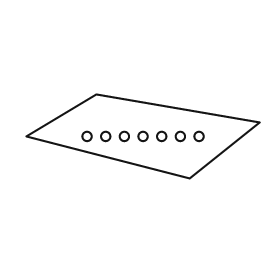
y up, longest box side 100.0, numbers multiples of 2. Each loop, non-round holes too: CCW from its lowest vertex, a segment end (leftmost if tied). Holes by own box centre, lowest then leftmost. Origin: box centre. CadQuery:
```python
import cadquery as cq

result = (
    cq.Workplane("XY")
    .moveTo(20.0, -18.0)
    .lineTo(50.0, 6.0)
    .lineTo(-20.0, 18.0)
    .lineTo(-50.0, 0.0)
    .close()
    .moveTo(-24.0, 0.0)
    .circle(2.0)
    .moveTo(-16.0, 0.0)
    .circle(2.0)
    .moveTo(-8.0, 0.0)
    .circle(2.0)
    .moveTo(0.0, 0.0)
    .circle(2.0)
    .moveTo(8.0, 0.0)
    .circle(2.0)
    .moveTo(16.0, 0.0)
    .circle(2.0)
    .moveTo(24.0, 0.0)
    .circle(2.0)
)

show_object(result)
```